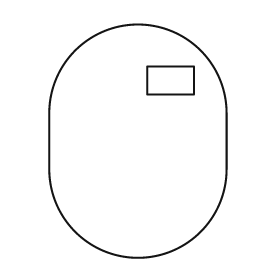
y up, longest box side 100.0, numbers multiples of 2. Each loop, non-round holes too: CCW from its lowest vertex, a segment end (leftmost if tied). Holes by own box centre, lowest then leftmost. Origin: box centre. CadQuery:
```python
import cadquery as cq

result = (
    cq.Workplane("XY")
    .moveTo(-38.0, -12.0)
    .threePointArc((0.0, -50.0), (38.0, -12.0))
    .lineTo(38.0, 12.0)
    .threePointArc((0.0, 50.0), (-38.0, 12.0))
    .close()
    .moveTo(4.0, 20.0)
    .lineTo(24.0, 20.0)
    .lineTo(24.0, 32.0)
    .lineTo(4.0, 32.0)
    .close()
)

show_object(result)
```